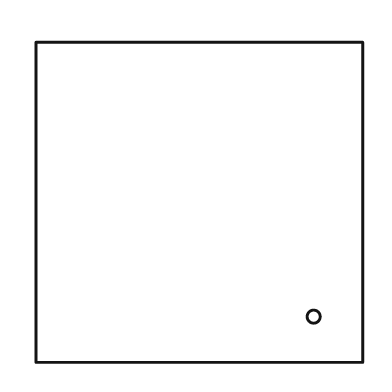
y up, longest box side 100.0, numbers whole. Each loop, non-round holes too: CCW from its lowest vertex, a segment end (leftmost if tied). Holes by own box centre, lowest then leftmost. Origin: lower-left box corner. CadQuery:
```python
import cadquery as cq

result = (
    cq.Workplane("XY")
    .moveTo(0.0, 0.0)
    .lineTo(100.0, 0.0)
    .lineTo(100.0, 98.0)
    .lineTo(0.0, 98.0)
    .close()
    .moveTo(85.0, 14.0)
    .circle(2.0)
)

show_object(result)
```